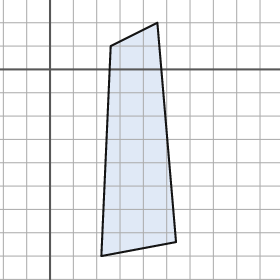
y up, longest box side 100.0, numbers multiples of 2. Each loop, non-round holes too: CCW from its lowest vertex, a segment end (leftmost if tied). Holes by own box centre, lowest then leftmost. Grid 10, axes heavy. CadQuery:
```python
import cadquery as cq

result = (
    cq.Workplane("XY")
    .moveTo(22.0, -80.0)
    .lineTo(54.0, -74.0)
    .lineTo(46.0, 20.0)
    .lineTo(26.0, 10.0)
    .close()
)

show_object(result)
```